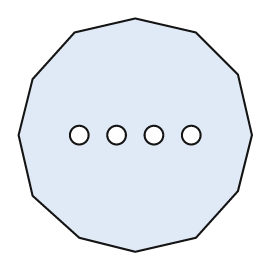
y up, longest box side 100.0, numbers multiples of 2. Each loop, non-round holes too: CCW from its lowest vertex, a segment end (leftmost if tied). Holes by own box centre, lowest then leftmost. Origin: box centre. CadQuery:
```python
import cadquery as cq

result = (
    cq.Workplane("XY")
    .moveTo(0.0, -50.0)
    .lineTo(26.0, -44.0)
    .lineTo(44.0, -24.0)
    .lineTo(50.0, 0.0)
    .lineTo(44.0, 26.0)
    .lineTo(26.0, 44.0)
    .lineTo(0.0, 50.0)
    .lineTo(-26.0, 44.0)
    .lineTo(-44.0, 24.0)
    .lineTo(-50.0, 0.0)
    .lineTo(-44.0, -26.0)
    .lineTo(-24.0, -44.0)
    .close()
    .moveTo(-24.0, 0.0)
    .circle(4.0)
    .moveTo(-8.0, 0.0)
    .circle(4.0)
    .moveTo(8.0, 0.0)
    .circle(4.0)
    .moveTo(24.0, 0.0)
    .circle(4.0)
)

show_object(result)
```